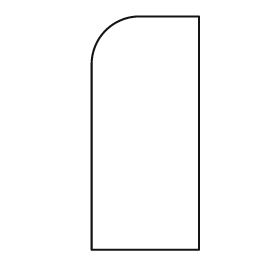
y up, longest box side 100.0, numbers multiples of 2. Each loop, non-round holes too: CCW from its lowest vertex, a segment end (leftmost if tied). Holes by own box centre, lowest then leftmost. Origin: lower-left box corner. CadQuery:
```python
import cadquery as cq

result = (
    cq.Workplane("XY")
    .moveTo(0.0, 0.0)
    .lineTo(46.0, 0.0)
    .lineTo(46.0, 100.0)
    .lineTo(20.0, 100.0)
    .threePointArc((6.0, 94.0), (0.0, 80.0))
    .close()
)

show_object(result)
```